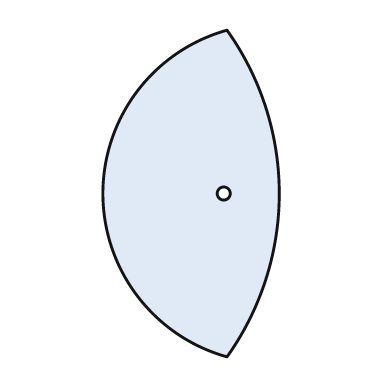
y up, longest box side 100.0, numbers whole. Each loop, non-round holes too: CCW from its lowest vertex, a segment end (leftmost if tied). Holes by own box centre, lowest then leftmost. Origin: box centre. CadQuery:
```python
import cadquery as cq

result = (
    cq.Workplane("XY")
    .moveTo(11.0, -50.0)
    .threePointArc((27.0, 0.0), (11.0, 50.0))
    .threePointArc((-27.0, 0.0), (11.0, -50.0))
    .close()
    .moveTo(10.0, 0.0)
    .circle(2.0)
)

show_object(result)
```